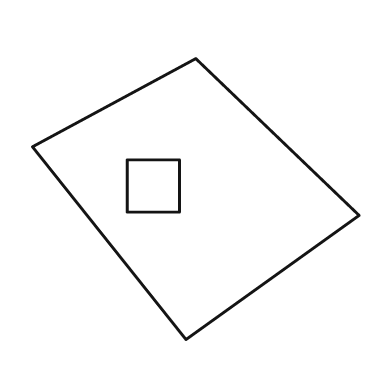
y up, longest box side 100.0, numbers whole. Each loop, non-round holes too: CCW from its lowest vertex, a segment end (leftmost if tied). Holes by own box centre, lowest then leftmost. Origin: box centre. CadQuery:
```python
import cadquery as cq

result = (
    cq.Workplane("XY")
    .moveTo(-3.0, -43.0)
    .lineTo(50.0, -5.0)
    .lineTo(0.0, 43.0)
    .lineTo(-50.0, 16.0)
    .close()
    .moveTo(-21.0, -4.0)
    .lineTo(-5.0, -4.0)
    .lineTo(-5.0, 12.0)
    .lineTo(-21.0, 12.0)
    .close()
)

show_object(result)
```